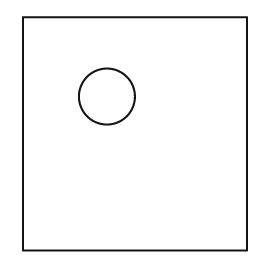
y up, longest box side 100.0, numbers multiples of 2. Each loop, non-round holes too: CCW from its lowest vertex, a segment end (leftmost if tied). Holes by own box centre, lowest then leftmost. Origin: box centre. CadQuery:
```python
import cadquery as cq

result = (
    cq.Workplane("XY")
    .moveTo(-48.0, -50.0)
    .lineTo(48.0, -50.0)
    .lineTo(48.0, 50.0)
    .lineTo(-48.0, 50.0)
    .close()
    .moveTo(-12.0, 16.0)
    .circle(12.0)
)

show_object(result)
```